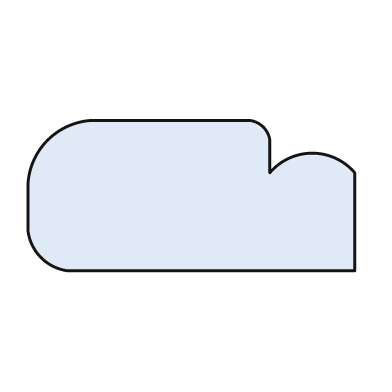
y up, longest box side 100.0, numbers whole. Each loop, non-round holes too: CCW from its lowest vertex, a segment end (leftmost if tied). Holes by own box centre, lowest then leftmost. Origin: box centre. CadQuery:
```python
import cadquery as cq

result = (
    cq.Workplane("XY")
    .moveTo(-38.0, -23.0)
    .lineTo(50.0, -23.0)
    .lineTo(50.0, 7.0)
    .threePointArc((37.0, 13.0), (24.0, 7.0))
    .lineTo(24.0, 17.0)
    .threePointArc((22.0, 21.0), (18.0, 23.0))
    .lineTo(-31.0, 23.0)
    .threePointArc((-44.0, 17.0), (-50.0, 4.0))
    .lineTo(-50.0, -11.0)
    .threePointArc((-46.0, -19.0), (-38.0, -23.0))
    .close()
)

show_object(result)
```